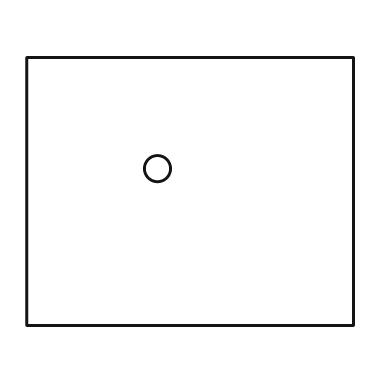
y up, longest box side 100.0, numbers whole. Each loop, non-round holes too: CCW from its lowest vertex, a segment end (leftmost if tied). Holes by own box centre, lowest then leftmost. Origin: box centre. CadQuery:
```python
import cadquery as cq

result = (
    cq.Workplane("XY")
    .moveTo(-50.0, -41.0)
    .lineTo(50.0, -41.0)
    .lineTo(50.0, 41.0)
    .lineTo(-50.0, 41.0)
    .close()
    .moveTo(-10.0, 7.0)
    .circle(4.0)
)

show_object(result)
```